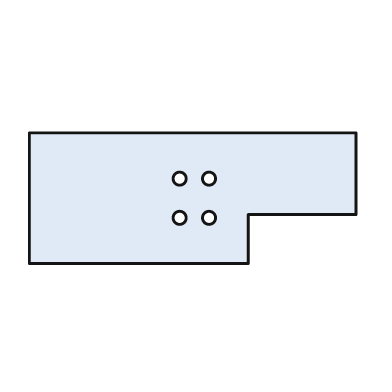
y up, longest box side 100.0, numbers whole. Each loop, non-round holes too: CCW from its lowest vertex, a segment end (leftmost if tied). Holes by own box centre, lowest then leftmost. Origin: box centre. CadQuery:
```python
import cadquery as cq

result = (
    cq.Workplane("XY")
    .moveTo(-50.0, -20.0)
    .lineTo(17.0, -20.0)
    .lineTo(17.0, -5.0)
    .lineTo(50.0, -5.0)
    .lineTo(50.0, 20.0)
    .lineTo(-50.0, 20.0)
    .close()
    .moveTo(-4.0, -6.0)
    .circle(2.0)
    .moveTo(5.0, -6.0)
    .circle(2.0)
    .moveTo(-4.0, 6.0)
    .circle(2.0)
    .moveTo(5.0, 6.0)
    .circle(2.0)
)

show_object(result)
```